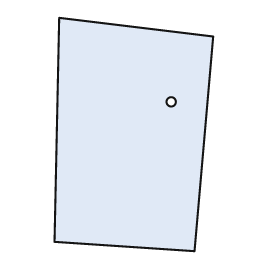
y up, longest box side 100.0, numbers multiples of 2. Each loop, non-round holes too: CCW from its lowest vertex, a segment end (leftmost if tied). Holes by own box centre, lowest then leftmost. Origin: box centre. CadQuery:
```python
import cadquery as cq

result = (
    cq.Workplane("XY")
    .moveTo(26.0, -50.0)
    .lineTo(34.0, 42.0)
    .lineTo(-32.0, 50.0)
    .lineTo(-34.0, -46.0)
    .close()
    .moveTo(16.0, 14.0)
    .circle(2.0)
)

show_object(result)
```